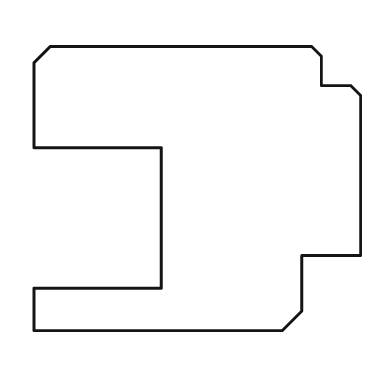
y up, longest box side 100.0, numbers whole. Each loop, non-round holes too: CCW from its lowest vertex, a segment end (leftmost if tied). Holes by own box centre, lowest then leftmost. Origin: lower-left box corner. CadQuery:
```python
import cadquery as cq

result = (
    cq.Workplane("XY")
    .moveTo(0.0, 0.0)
    .lineTo(76.0, 0.0)
    .lineTo(82.0, 6.0)
    .lineTo(82.0, 23.0)
    .lineTo(100.0, 23.0)
    .lineTo(100.0, 72.0)
    .lineTo(97.0, 75.0)
    .lineTo(88.0, 75.0)
    .lineTo(88.0, 84.0)
    .lineTo(85.0, 87.0)
    .lineTo(5.0, 87.0)
    .lineTo(0.0, 82.0)
    .lineTo(0.0, 56.0)
    .lineTo(39.0, 56.0)
    .lineTo(39.0, 13.0)
    .lineTo(0.0, 13.0)
    .close()
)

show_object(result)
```